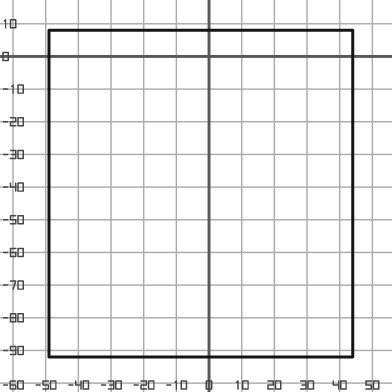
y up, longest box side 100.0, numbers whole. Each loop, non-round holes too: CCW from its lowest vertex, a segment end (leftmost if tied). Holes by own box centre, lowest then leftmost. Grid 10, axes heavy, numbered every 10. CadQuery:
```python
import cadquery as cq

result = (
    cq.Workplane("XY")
    .moveTo(-49.0, -92.0)
    .lineTo(44.0, -92.0)
    .lineTo(44.0, 8.0)
    .lineTo(-49.0, 8.0)
    .close()
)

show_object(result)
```